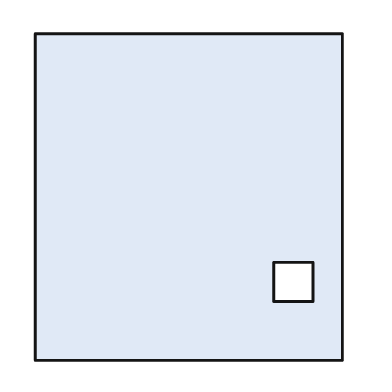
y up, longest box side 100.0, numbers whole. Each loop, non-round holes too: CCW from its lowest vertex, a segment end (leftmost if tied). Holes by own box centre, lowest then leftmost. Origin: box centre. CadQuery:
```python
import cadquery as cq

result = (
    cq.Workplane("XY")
    .moveTo(-47.0, -50.0)
    .lineTo(47.0, -50.0)
    .lineTo(47.0, 50.0)
    .lineTo(-47.0, 50.0)
    .close()
    .moveTo(26.0, -32.0)
    .lineTo(38.0, -32.0)
    .lineTo(38.0, -20.0)
    .lineTo(26.0, -20.0)
    .close()
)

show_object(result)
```